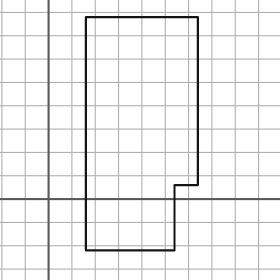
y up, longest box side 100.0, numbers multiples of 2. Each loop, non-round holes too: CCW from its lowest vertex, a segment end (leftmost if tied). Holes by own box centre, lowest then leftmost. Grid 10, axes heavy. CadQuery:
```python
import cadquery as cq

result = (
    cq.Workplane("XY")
    .moveTo(16.0, -22.0)
    .lineTo(54.0, -22.0)
    .lineTo(54.0, 6.0)
    .lineTo(64.0, 6.0)
    .lineTo(64.0, 78.0)
    .lineTo(16.0, 78.0)
    .close()
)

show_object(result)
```